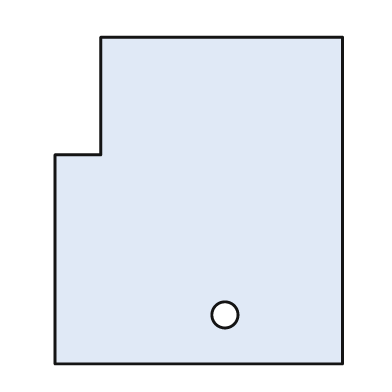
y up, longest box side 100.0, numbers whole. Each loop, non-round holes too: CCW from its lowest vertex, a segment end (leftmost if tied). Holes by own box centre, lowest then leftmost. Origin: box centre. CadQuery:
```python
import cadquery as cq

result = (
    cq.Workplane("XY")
    .moveTo(-44.0, -50.0)
    .lineTo(44.0, -50.0)
    .lineTo(44.0, 50.0)
    .lineTo(-30.0, 50.0)
    .lineTo(-30.0, 14.0)
    .lineTo(-44.0, 14.0)
    .close()
    .moveTo(8.0, -35.0)
    .circle(4.0)
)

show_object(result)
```